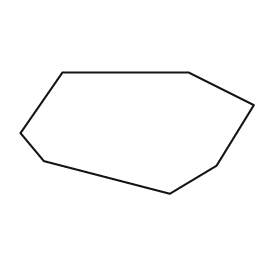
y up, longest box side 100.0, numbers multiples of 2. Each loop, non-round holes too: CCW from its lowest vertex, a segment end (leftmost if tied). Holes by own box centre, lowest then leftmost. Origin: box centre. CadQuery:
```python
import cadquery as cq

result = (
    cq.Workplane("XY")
    .moveTo(14.0, -26.0)
    .lineTo(34.0, -14.0)
    .lineTo(50.0, 12.0)
    .lineTo(22.0, 26.0)
    .lineTo(-32.0, 26.0)
    .lineTo(-50.0, 0.0)
    .lineTo(-40.0, -12.0)
    .close()
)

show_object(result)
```